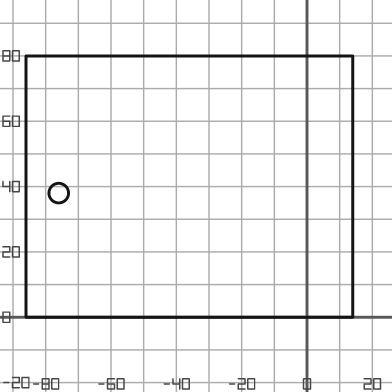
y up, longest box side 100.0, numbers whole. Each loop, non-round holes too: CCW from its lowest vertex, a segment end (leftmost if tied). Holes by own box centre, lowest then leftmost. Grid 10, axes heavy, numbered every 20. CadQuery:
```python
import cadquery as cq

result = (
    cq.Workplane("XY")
    .moveTo(-86.0, 0.0)
    .lineTo(14.0, 0.0)
    .lineTo(14.0, 80.0)
    .lineTo(-86.0, 80.0)
    .close()
    .moveTo(-76.0, 38.0)
    .circle(3.0)
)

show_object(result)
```